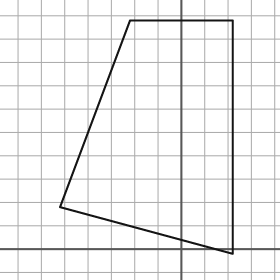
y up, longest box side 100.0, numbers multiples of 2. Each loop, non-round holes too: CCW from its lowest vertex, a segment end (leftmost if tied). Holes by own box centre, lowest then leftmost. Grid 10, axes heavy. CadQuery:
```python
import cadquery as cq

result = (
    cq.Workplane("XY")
    .moveTo(22.0, -2.0)
    .lineTo(22.0, 98.0)
    .lineTo(-22.0, 98.0)
    .lineTo(-52.0, 18.0)
    .close()
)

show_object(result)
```